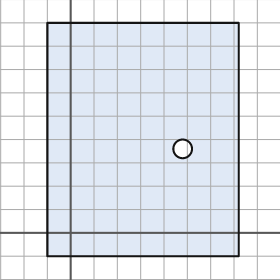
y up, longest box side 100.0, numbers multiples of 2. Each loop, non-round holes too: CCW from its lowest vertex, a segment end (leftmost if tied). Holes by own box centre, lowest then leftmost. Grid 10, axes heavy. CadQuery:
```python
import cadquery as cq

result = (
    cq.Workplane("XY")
    .moveTo(-10.0, -10.0)
    .lineTo(72.0, -10.0)
    .lineTo(72.0, 90.0)
    .lineTo(-10.0, 90.0)
    .close()
    .moveTo(48.0, 36.0)
    .circle(4.0)
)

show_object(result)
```